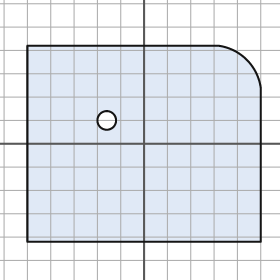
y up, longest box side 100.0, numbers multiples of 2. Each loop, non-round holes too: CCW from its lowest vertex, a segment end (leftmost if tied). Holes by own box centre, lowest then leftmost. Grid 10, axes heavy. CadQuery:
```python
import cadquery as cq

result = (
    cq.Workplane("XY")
    .moveTo(-50.0, -42.0)
    .lineTo(50.0, -42.0)
    .lineTo(50.0, 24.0)
    .threePointArc((44.0, 36.0), (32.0, 42.0))
    .lineTo(-50.0, 42.0)
    .close()
    .moveTo(-16.0, 10.0)
    .circle(4.0)
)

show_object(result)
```